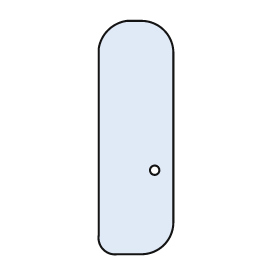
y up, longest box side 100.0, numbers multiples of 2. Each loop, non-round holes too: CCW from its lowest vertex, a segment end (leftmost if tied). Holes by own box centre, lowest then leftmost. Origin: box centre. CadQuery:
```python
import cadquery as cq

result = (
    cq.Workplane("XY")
    .moveTo(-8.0, -50.0)
    .lineTo(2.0, -50.0)
    .threePointArc((12.0, -46.0), (16.0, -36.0))
    .lineTo(16.0, 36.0)
    .threePointArc((12.0, 46.0), (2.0, 50.0))
    .lineTo(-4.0, 50.0)
    .threePointArc((-12.0, 46.0), (-16.0, 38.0))
    .lineTo(-16.0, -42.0)
    .threePointArc((-14.0, -48.0), (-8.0, -50.0))
    .close()
    .moveTo(8.0, -14.0)
    .circle(2.0)
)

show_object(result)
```